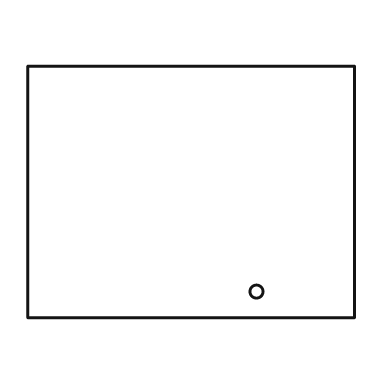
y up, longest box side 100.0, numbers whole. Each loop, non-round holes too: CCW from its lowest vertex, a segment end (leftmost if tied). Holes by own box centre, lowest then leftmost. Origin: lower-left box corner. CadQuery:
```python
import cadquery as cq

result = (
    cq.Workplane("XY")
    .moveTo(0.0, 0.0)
    .lineTo(100.0, 0.0)
    .lineTo(100.0, 77.0)
    .lineTo(0.0, 77.0)
    .close()
    .moveTo(70.0, 8.0)
    .circle(2.0)
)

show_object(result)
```